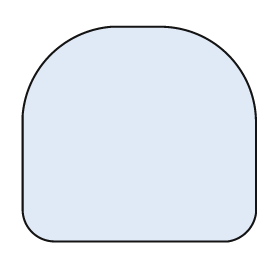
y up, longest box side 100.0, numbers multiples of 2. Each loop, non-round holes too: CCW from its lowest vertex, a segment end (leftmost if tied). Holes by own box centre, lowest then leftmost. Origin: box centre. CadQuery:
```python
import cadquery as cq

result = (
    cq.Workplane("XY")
    .moveTo(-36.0, -46.0)
    .lineTo(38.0, -46.0)
    .threePointArc((46.0, -42.0), (50.0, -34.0))
    .lineTo(50.0, 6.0)
    .threePointArc((38.0, 34.0), (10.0, 46.0))
    .lineTo(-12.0, 46.0)
    .threePointArc((-38.0, 34.0), (-50.0, 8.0))
    .lineTo(-50.0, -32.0)
    .threePointArc((-46.0, -42.0), (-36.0, -46.0))
    .close()
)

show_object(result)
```